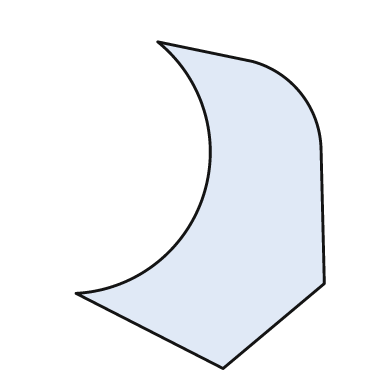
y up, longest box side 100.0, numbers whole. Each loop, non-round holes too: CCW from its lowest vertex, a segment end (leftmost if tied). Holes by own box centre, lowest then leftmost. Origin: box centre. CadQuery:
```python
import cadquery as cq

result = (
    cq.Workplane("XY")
    .moveTo(7.0, -50.0)
    .lineTo(38.0, -24.0)
    .lineTo(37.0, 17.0)
    .threePointArc((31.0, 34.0), (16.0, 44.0))
    .lineTo(-13.0, 50.0)
    .threePointArc((1.0, 3.0), (-38.0, -27.0))
    .close()
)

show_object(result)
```